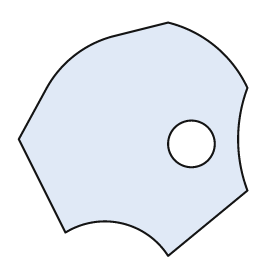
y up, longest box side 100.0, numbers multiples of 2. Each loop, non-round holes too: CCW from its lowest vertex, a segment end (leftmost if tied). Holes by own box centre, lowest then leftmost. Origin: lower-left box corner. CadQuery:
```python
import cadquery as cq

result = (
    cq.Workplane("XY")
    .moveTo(64.0, 0.0)
    .lineTo(98.0, 28.0)
    .threePointArc((94.0, 50.0), (98.0, 72.0))
    .threePointArc((84.0, 90.0), (64.0, 100.0))
    .lineTo(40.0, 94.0)
    .threePointArc((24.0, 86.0), (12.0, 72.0))
    .lineTo(0.0, 50.0)
    .lineTo(20.0, 10.0)
    .threePointArc((44.0, 14.0), (64.0, 0.0))
    .close()
    .moveTo(74.0, 48.0)
    .circle(10.0)
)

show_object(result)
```